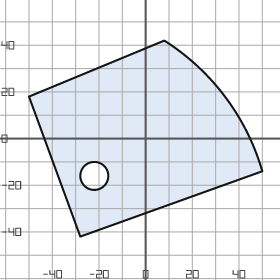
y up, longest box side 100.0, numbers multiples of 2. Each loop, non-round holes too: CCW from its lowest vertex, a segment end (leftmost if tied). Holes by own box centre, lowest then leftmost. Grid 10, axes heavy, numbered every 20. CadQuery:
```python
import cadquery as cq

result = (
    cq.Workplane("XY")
    .moveTo(-28.0, -42.0)
    .lineTo(50.0, -14.0)
    .threePointArc((34.0, 18.0), (8.0, 42.0))
    .lineTo(-50.0, 18.0)
    .close()
    .moveTo(-22.0, -16.0)
    .circle(6.0)
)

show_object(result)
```